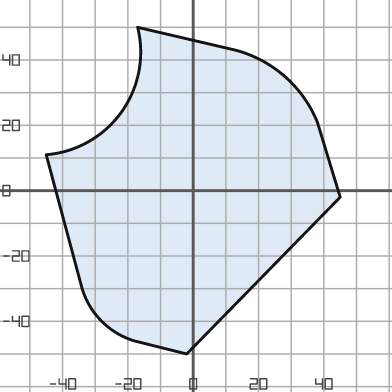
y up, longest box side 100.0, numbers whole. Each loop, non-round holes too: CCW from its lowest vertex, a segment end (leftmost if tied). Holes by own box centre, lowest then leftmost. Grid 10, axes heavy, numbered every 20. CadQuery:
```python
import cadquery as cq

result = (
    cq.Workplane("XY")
    .moveTo(-2.0, -50.0)
    .lineTo(45.0, -2.0)
    .lineTo(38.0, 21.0)
    .threePointArc((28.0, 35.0), (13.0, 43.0))
    .lineTo(-17.0, 50.0)
    .threePointArc((-22.0, 24.0), (-45.0, 11.0))
    .lineTo(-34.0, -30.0)
    .threePointArc((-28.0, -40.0), (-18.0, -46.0))
    .close()
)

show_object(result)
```